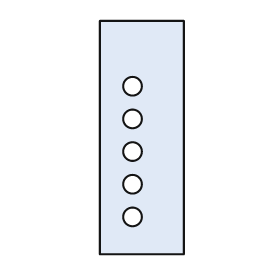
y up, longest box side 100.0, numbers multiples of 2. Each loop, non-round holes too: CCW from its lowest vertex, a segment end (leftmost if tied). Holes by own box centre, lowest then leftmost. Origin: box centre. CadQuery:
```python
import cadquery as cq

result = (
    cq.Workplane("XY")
    .moveTo(-18.0, -50.0)
    .lineTo(18.0, -50.0)
    .lineTo(18.0, 50.0)
    .lineTo(-18.0, 50.0)
    .close()
    .moveTo(-4.0, -34.0)
    .circle(4.0)
    .moveTo(-4.0, -20.0)
    .circle(4.0)
    .moveTo(-4.0, -6.0)
    .circle(4.0)
    .moveTo(-4.0, 8.0)
    .circle(4.0)
    .moveTo(-4.0, 22.0)
    .circle(4.0)
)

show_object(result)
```